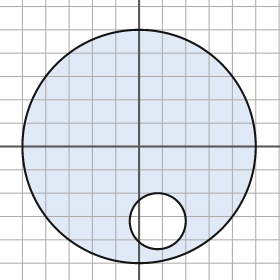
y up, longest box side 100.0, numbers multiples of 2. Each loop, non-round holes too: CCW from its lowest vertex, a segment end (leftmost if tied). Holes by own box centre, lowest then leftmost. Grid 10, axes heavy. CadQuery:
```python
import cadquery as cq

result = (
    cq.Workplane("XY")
    .moveTo(0.0, 0.0)
    .circle(50.0)
    .moveTo(8.0, -32.0)
    .circle(12.0)
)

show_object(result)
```